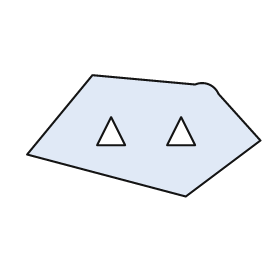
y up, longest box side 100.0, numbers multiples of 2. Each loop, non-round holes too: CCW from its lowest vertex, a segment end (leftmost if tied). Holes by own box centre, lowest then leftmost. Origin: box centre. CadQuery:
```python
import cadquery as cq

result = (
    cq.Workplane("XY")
    .moveTo(18.0, -26.0)
    .lineTo(50.0, -2.0)
    .lineTo(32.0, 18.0)
    .threePointArc((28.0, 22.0), (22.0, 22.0))
    .lineTo(-22.0, 26.0)
    .lineTo(-50.0, -8.0)
    .close()
    .moveTo(-20.0, -4.0)
    .lineTo(-8.0, -4.0)
    .lineTo(-14.0, 8.0)
    .close()
    .moveTo(10.0, -4.0)
    .lineTo(22.0, -4.0)
    .lineTo(16.0, 8.0)
    .close()
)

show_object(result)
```